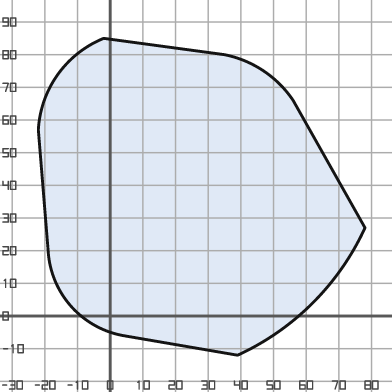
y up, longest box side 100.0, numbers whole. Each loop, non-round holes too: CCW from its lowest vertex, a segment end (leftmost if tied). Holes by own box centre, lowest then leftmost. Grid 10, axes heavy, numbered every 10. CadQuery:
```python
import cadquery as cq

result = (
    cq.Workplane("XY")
    .moveTo(39.0, -12.0)
    .threePointArc((62.0, 4.0), (78.0, 27.0))
    .lineTo(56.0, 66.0)
    .threePointArc((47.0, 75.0), (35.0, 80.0))
    .lineTo(-2.0, 85.0)
    .threePointArc((-16.0, 74.0), (-22.0, 57.0))
    .lineTo(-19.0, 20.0)
    .threePointArc((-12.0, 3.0), (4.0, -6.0))
    .close()
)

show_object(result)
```